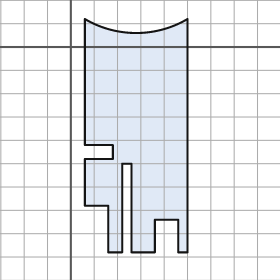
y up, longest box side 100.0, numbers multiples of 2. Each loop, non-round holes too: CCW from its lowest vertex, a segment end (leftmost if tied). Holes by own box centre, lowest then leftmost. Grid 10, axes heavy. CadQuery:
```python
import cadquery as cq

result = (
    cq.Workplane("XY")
    .moveTo(16.0, -88.0)
    .lineTo(22.0, -88.0)
    .lineTo(22.0, -50.0)
    .lineTo(26.0, -50.0)
    .lineTo(26.0, -88.0)
    .lineTo(36.0, -88.0)
    .lineTo(36.0, -74.0)
    .lineTo(46.0, -74.0)
    .lineTo(46.0, -88.0)
    .lineTo(50.0, -88.0)
    .lineTo(50.0, 12.0)
    .threePointArc((28.0, 6.0), (6.0, 12.0))
    .lineTo(6.0, -42.0)
    .lineTo(18.0, -42.0)
    .lineTo(18.0, -48.0)
    .lineTo(6.0, -48.0)
    .lineTo(6.0, -68.0)
    .lineTo(16.0, -68.0)
    .close()
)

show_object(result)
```